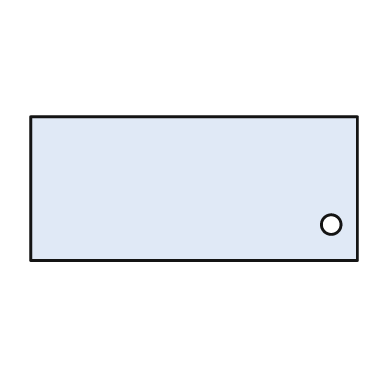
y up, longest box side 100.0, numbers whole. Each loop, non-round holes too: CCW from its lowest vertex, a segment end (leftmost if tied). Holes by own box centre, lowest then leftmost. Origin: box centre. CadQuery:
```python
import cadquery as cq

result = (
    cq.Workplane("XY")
    .moveTo(-50.0, -22.0)
    .lineTo(50.0, -22.0)
    .lineTo(50.0, 22.0)
    .lineTo(-50.0, 22.0)
    .close()
    .moveTo(42.0, -11.0)
    .circle(3.0)
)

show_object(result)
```